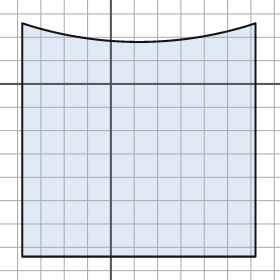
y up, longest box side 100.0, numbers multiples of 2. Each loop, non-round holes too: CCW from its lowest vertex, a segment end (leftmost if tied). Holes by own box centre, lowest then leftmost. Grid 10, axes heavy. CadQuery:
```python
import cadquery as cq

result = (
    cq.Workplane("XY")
    .moveTo(-38.0, -74.0)
    .lineTo(62.0, -74.0)
    .lineTo(62.0, 26.0)
    .threePointArc((12.0, 18.0), (-38.0, 26.0))
    .close()
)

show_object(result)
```